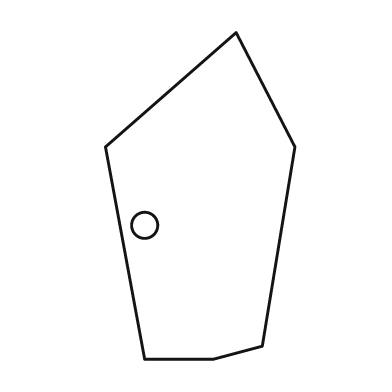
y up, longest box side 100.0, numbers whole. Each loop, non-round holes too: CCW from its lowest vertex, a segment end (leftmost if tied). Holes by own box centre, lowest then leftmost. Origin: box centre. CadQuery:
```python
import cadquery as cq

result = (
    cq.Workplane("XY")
    .moveTo(-17.0, -50.0)
    .lineTo(4.0, -50.0)
    .lineTo(19.0, -46.0)
    .lineTo(29.0, 15.0)
    .lineTo(11.0, 50.0)
    .lineTo(-29.0, 15.0)
    .close()
    .moveTo(-17.0, -9.0)
    .circle(4.0)
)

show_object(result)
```